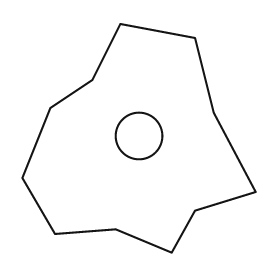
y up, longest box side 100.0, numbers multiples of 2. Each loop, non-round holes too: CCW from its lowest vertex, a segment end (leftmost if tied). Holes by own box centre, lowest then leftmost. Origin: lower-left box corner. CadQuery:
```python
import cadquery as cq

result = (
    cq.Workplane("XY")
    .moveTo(64.0, 0.0)
    .lineTo(74.0, 18.0)
    .lineTo(100.0, 26.0)
    .lineTo(82.0, 60.0)
    .lineTo(74.0, 92.0)
    .lineTo(42.0, 98.0)
    .lineTo(30.0, 74.0)
    .lineTo(12.0, 62.0)
    .lineTo(0.0, 32.0)
    .lineTo(14.0, 8.0)
    .lineTo(40.0, 10.0)
    .close()
    .moveTo(50.0, 50.0)
    .circle(10.0)
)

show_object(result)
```